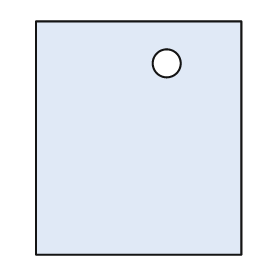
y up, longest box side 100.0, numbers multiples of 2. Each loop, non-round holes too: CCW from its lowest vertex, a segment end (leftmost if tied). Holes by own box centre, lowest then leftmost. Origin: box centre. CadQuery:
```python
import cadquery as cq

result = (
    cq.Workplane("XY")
    .moveTo(-44.0, -50.0)
    .lineTo(44.0, -50.0)
    .lineTo(44.0, 50.0)
    .lineTo(-44.0, 50.0)
    .close()
    .moveTo(12.0, 32.0)
    .circle(6.0)
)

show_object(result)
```